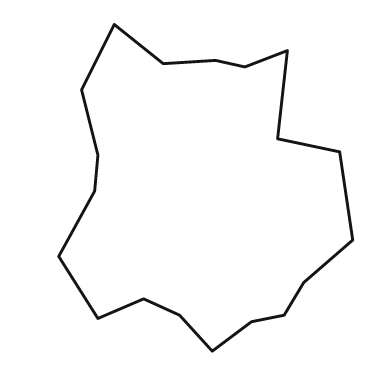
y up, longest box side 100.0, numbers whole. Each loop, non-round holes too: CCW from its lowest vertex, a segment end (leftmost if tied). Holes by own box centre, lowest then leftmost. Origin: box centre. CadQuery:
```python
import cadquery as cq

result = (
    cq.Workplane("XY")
    .moveTo(2.0, -50.0)
    .lineTo(14.0, -41.0)
    .lineTo(24.0, -39.0)
    .lineTo(30.0, -29.0)
    .lineTo(45.0, -16.0)
    .lineTo(41.0, 11.0)
    .lineTo(22.0, 15.0)
    .lineTo(25.0, 42.0)
    .lineTo(12.0, 37.0)
    .lineTo(3.0, 39.0)
    .lineTo(-13.0, 38.0)
    .lineTo(-28.0, 50.0)
    .lineTo(-38.0, 30.0)
    .lineTo(-33.0, 10.0)
    .lineTo(-34.0, -1.0)
    .lineTo(-45.0, -21.0)
    .lineTo(-33.0, -40.0)
    .lineTo(-19.0, -34.0)
    .lineTo(-8.0, -39.0)
    .close()
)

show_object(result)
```